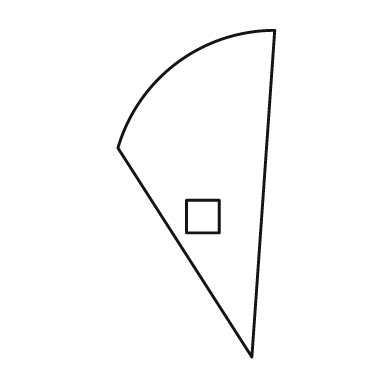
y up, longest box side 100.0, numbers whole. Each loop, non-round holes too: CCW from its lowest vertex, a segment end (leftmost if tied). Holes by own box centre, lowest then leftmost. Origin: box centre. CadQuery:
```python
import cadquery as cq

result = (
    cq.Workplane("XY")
    .moveTo(17.0, -50.0)
    .lineTo(24.0, 50.0)
    .threePointArc((-6.0, 40.0), (-24.0, 14.0))
    .close()
    .moveTo(-3.0, -12.0)
    .lineTo(7.0, -12.0)
    .lineTo(7.0, -2.0)
    .lineTo(-3.0, -2.0)
    .close()
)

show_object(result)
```